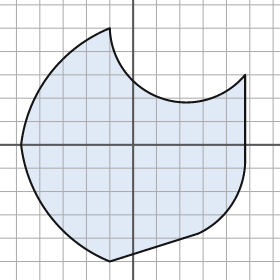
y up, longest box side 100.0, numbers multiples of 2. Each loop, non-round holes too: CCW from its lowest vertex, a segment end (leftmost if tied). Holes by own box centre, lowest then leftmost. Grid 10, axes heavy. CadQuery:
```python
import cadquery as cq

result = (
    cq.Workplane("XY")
    .moveTo(-10.0, -50.0)
    .lineTo(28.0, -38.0)
    .threePointArc((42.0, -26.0), (48.0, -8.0))
    .lineTo(48.0, 30.0)
    .threePointArc((12.0, 20.0), (-10.0, 50.0))
    .threePointArc((-36.0, 30.0), (-48.0, 0.0))
    .threePointArc((-36.0, -30.0), (-10.0, -50.0))
    .close()
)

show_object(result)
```